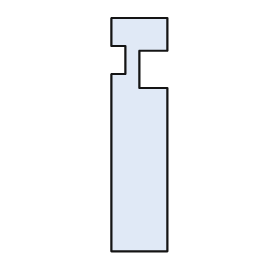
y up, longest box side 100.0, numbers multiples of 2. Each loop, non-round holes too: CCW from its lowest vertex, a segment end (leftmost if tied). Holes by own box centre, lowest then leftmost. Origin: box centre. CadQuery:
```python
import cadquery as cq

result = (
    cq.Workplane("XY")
    .moveTo(-12.0, -50.0)
    .lineTo(12.0, -50.0)
    .lineTo(12.0, 20.0)
    .lineTo(0.0, 20.0)
    .lineTo(0.0, 36.0)
    .lineTo(12.0, 36.0)
    .lineTo(12.0, 50.0)
    .lineTo(-12.0, 50.0)
    .lineTo(-12.0, 38.0)
    .lineTo(-6.0, 38.0)
    .lineTo(-6.0, 26.0)
    .lineTo(-12.0, 26.0)
    .close()
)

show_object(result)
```